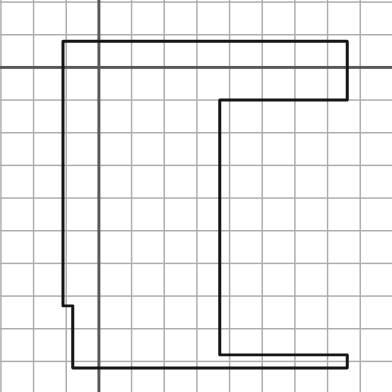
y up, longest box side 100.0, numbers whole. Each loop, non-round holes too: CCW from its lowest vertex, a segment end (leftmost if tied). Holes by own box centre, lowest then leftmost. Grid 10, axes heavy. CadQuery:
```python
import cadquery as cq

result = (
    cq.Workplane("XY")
    .moveTo(-8.0, -92.0)
    .lineTo(76.0, -92.0)
    .lineTo(76.0, -88.0)
    .lineTo(37.0, -88.0)
    .lineTo(37.0, -10.0)
    .lineTo(76.0, -10.0)
    .lineTo(76.0, 8.0)
    .lineTo(-11.0, 8.0)
    .lineTo(-11.0, -73.0)
    .lineTo(-8.0, -73.0)
    .close()
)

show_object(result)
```